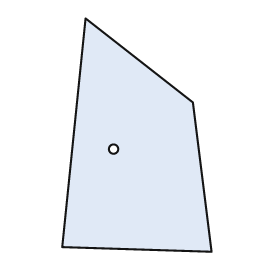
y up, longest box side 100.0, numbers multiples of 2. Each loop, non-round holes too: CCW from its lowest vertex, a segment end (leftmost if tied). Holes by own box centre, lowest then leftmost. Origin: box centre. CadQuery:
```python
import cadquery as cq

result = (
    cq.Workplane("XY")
    .moveTo(32.0, -50.0)
    .lineTo(24.0, 14.0)
    .lineTo(-22.0, 50.0)
    .lineTo(-32.0, -48.0)
    .close()
    .moveTo(-10.0, -6.0)
    .circle(2.0)
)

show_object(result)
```